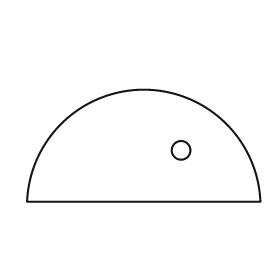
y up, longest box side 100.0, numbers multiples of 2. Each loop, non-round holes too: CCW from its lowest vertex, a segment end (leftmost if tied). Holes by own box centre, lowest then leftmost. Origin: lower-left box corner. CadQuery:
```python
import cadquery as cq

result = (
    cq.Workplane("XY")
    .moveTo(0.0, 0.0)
    .lineTo(100.0, 0.0)
    .threePointArc((50.0, 48.0), (0.0, 0.0))
    .close()
    .moveTo(66.0, 22.0)
    .circle(4.0)
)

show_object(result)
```